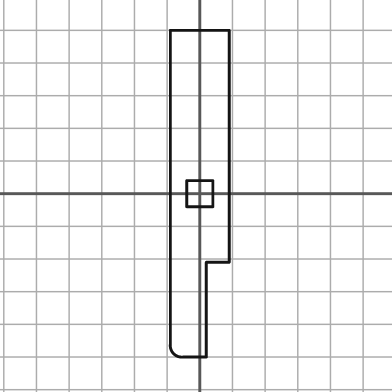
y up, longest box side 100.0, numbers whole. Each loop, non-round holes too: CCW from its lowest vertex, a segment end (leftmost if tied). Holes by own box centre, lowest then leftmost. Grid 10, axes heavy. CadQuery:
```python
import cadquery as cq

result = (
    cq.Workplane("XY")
    .moveTo(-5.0, -50.0)
    .lineTo(2.0, -50.0)
    .lineTo(2.0, -21.0)
    .lineTo(9.0, -21.0)
    .lineTo(9.0, 50.0)
    .lineTo(-9.0, 50.0)
    .lineTo(-9.0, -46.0)
    .threePointArc((-8.0, -49.0), (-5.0, -50.0))
    .close()
    .moveTo(-4.0, -4.0)
    .lineTo(4.0, -4.0)
    .lineTo(4.0, 4.0)
    .lineTo(-4.0, 4.0)
    .close()
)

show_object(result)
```